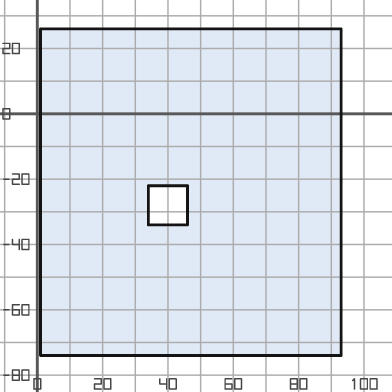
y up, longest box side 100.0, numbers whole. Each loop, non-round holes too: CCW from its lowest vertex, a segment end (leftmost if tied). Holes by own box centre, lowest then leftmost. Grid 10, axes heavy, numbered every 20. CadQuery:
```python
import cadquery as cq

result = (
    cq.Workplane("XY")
    .moveTo(1.0, -74.0)
    .lineTo(93.0, -74.0)
    .lineTo(93.0, 26.0)
    .lineTo(1.0, 26.0)
    .close()
    .moveTo(34.0, -34.0)
    .lineTo(46.0, -34.0)
    .lineTo(46.0, -22.0)
    .lineTo(34.0, -22.0)
    .close()
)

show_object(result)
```